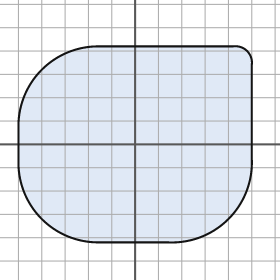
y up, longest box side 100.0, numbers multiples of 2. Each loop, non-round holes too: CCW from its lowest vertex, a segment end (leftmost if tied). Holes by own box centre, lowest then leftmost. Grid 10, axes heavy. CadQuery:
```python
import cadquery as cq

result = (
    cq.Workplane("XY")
    .moveTo(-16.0, -42.0)
    .lineTo(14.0, -42.0)
    .threePointArc((40.0, -32.0), (50.0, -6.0))
    .lineTo(50.0, 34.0)
    .threePointArc((48.0, 40.0), (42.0, 42.0))
    .lineTo(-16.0, 42.0)
    .threePointArc((-40.0, 32.0), (-50.0, 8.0))
    .lineTo(-50.0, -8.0)
    .threePointArc((-40.0, -32.0), (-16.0, -42.0))
    .close()
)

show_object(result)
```